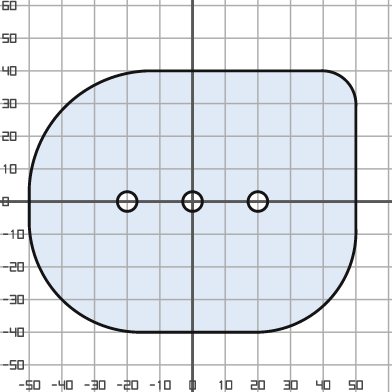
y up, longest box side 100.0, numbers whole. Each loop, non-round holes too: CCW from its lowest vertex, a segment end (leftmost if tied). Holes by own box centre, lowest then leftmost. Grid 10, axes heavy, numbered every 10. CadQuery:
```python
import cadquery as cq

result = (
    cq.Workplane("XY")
    .moveTo(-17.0, -40.0)
    .lineTo(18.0, -40.0)
    .threePointArc((41.0, -31.0), (50.0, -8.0))
    .lineTo(50.0, 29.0)
    .threePointArc((47.0, 37.0), (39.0, 40.0))
    .lineTo(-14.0, 40.0)
    .threePointArc((-39.0, 29.0), (-50.0, 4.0))
    .lineTo(-50.0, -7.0)
    .threePointArc((-40.0, -30.0), (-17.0, -40.0))
    .close()
    .moveTo(-20.0, 0.0)
    .circle(3.0)
    .moveTo(0.0, 0.0)
    .circle(3.0)
    .moveTo(20.0, 0.0)
    .circle(3.0)
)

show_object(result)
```